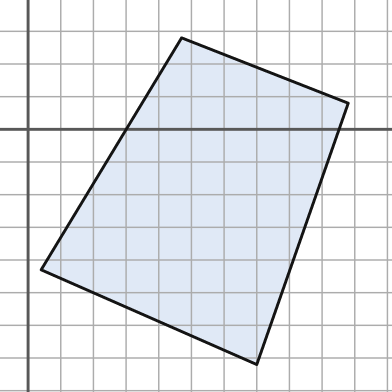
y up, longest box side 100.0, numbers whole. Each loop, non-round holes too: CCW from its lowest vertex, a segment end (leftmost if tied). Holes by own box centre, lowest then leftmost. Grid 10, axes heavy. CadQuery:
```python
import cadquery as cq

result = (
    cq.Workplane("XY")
    .moveTo(70.0, -72.0)
    .lineTo(98.0, 8.0)
    .lineTo(47.0, 28.0)
    .lineTo(4.0, -43.0)
    .close()
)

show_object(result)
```